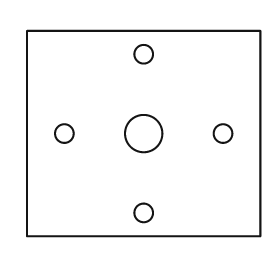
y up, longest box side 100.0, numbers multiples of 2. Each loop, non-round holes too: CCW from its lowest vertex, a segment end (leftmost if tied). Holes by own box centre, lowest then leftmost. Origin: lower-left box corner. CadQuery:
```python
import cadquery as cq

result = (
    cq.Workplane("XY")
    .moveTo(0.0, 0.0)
    .lineTo(100.0, 0.0)
    .lineTo(100.0, 88.0)
    .lineTo(0.0, 88.0)
    .close()
    .moveTo(50.0, 10.0)
    .circle(4.0)
    .moveTo(16.0, 44.0)
    .circle(4.0)
    .moveTo(50.0, 44.0)
    .circle(8.0)
    .moveTo(84.0, 44.0)
    .circle(4.0)
    .moveTo(50.0, 78.0)
    .circle(4.0)
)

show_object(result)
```